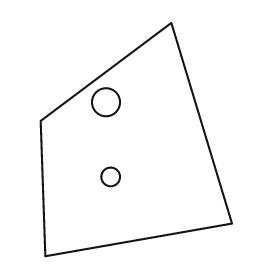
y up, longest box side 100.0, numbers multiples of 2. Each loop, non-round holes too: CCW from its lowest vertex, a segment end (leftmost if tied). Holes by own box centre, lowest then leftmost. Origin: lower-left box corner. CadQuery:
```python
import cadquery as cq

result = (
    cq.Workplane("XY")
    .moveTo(2.0, 0.0)
    .lineTo(82.0, 14.0)
    .lineTo(56.0, 100.0)
    .lineTo(0.0, 58.0)
    .close()
    .moveTo(30.0, 34.0)
    .circle(4.0)
    .moveTo(28.0, 66.0)
    .circle(6.0)
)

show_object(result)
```